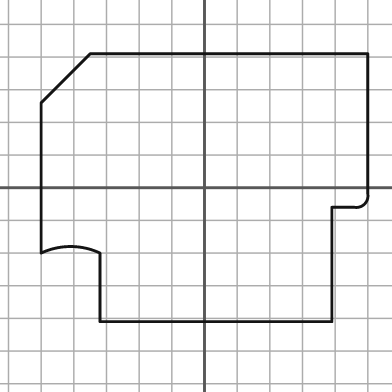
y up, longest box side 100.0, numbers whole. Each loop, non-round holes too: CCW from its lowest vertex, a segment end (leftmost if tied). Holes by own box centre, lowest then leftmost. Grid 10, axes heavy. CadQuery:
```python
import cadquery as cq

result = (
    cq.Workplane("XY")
    .moveTo(-32.0, -41.0)
    .lineTo(39.0, -41.0)
    .lineTo(39.0, -6.0)
    .lineTo(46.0, -6.0)
    .threePointArc((49.0, -5.0), (50.0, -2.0))
    .lineTo(50.0, 41.0)
    .lineTo(-35.0, 41.0)
    .lineTo(-50.0, 26.0)
    .lineTo(-50.0, -20.0)
    .threePointArc((-41.0, -18.0), (-32.0, -20.0))
    .close()
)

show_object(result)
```